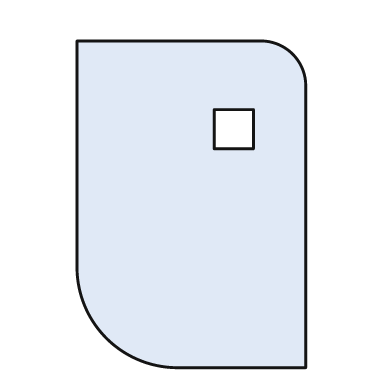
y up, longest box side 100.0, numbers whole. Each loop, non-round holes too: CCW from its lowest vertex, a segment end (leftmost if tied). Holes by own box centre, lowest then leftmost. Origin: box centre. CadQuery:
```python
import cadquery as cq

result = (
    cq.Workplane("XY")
    .moveTo(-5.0, -50.0)
    .lineTo(35.0, -50.0)
    .lineTo(35.0, 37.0)
    .threePointArc((31.0, 46.0), (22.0, 50.0))
    .lineTo(-35.0, 50.0)
    .lineTo(-35.0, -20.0)
    .threePointArc((-26.0, -41.0), (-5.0, -50.0))
    .close()
    .moveTo(7.0, 17.0)
    .lineTo(19.0, 17.0)
    .lineTo(19.0, 29.0)
    .lineTo(7.0, 29.0)
    .close()
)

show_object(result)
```